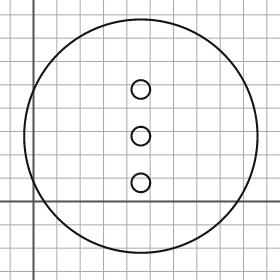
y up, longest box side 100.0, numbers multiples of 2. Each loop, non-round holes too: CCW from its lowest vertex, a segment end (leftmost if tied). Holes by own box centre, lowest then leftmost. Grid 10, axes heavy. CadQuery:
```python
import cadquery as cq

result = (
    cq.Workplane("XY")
    .moveTo(46.0, 28.0)
    .circle(50.0)
    .moveTo(46.0, 8.0)
    .circle(4.0)
    .moveTo(46.0, 28.0)
    .circle(4.0)
    .moveTo(46.0, 48.0)
    .circle(4.0)
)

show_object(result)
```